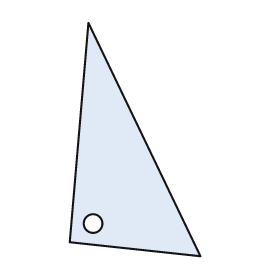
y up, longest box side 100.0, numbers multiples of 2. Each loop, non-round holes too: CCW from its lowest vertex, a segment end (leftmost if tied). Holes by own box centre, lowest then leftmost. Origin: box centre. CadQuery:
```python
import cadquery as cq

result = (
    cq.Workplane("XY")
    .moveTo(28.0, -50.0)
    .lineTo(-20.0, 50.0)
    .lineTo(-28.0, -44.0)
    .close()
    .moveTo(-18.0, -36.0)
    .circle(4.0)
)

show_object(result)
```